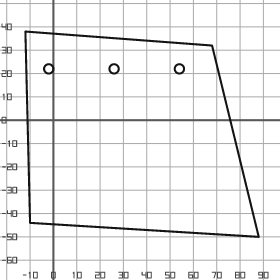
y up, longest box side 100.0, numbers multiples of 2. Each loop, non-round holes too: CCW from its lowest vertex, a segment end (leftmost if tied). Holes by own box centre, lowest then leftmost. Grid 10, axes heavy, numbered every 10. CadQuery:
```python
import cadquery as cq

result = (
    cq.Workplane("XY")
    .moveTo(88.0, -50.0)
    .lineTo(68.0, 32.0)
    .lineTo(-12.0, 38.0)
    .lineTo(-10.0, -44.0)
    .close()
    .moveTo(-2.0, 22.0)
    .circle(2.0)
    .moveTo(26.0, 22.0)
    .circle(2.0)
    .moveTo(54.0, 22.0)
    .circle(2.0)
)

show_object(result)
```